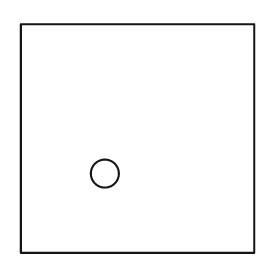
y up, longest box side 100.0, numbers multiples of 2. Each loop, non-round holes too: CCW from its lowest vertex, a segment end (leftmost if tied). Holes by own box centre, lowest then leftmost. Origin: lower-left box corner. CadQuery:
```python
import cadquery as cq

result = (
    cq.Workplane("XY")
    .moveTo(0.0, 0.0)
    .lineTo(100.0, 0.0)
    .lineTo(100.0, 98.0)
    .lineTo(0.0, 98.0)
    .close()
    .moveTo(36.0, 34.0)
    .circle(6.0)
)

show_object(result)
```